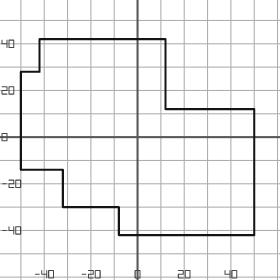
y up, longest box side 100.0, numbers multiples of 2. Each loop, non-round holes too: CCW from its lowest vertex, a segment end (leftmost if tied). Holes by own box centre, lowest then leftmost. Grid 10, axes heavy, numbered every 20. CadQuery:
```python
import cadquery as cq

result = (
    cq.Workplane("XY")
    .moveTo(-8.0, -42.0)
    .lineTo(50.0, -42.0)
    .lineTo(50.0, 12.0)
    .lineTo(12.0, 12.0)
    .lineTo(12.0, 42.0)
    .lineTo(-42.0, 42.0)
    .lineTo(-42.0, 28.0)
    .lineTo(-50.0, 28.0)
    .lineTo(-50.0, -14.0)
    .lineTo(-32.0, -14.0)
    .lineTo(-32.0, -30.0)
    .lineTo(-8.0, -30.0)
    .close()
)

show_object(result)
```